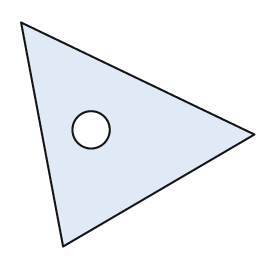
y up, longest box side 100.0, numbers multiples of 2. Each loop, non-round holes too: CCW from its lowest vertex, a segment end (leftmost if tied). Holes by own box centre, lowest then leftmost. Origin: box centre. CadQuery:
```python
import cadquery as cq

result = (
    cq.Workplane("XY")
    .moveTo(-32.0, -48.0)
    .lineTo(50.0, 0.0)
    .lineTo(-50.0, 48.0)
    .close()
    .moveTo(-20.0, 2.0)
    .circle(8.0)
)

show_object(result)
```